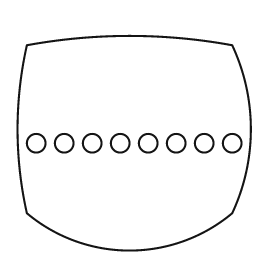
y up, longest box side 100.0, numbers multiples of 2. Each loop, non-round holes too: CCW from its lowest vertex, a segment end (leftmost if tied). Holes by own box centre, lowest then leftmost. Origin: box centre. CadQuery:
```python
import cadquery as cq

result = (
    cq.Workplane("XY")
    .moveTo(-46.0, -30.0)
    .threePointArc((-2.0, -46.0), (42.0, -30.0))
    .threePointArc((50.0, 6.0), (42.0, 42.0))
    .threePointArc((-2.0, 46.0), (-46.0, 42.0))
    .threePointArc((-50.0, 6.0), (-46.0, -30.0))
    .close()
    .moveTo(-42.0, 0.0)
    .circle(4.0)
    .moveTo(-30.0, 0.0)
    .circle(4.0)
    .moveTo(-18.0, 0.0)
    .circle(4.0)
    .moveTo(-6.0, 0.0)
    .circle(4.0)
    .moveTo(6.0, 0.0)
    .circle(4.0)
    .moveTo(18.0, 0.0)
    .circle(4.0)
    .moveTo(30.0, 0.0)
    .circle(4.0)
    .moveTo(42.0, 0.0)
    .circle(4.0)
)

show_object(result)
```